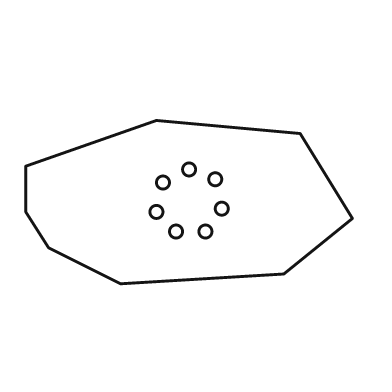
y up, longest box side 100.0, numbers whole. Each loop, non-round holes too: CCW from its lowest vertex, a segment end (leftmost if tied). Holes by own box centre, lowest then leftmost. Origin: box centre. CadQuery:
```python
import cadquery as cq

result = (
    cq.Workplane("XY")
    .moveTo(-21.0, -25.0)
    .lineTo(29.0, -22.0)
    .lineTo(50.0, -5.0)
    .lineTo(34.0, 21.0)
    .lineTo(-10.0, 25.0)
    .lineTo(-50.0, 11.0)
    .lineTo(-50.0, -3.0)
    .lineTo(-43.0, -14.0)
    .close()
    .moveTo(-4.0, -9.0)
    .circle(2.0)
    .moveTo(5.0, -9.0)
    .circle(2.0)
    .moveTo(-10.0, -3.0)
    .circle(2.0)
    .moveTo(10.0, -2.0)
    .circle(2.0)
    .moveTo(-8.0, 6.0)
    .circle(2.0)
    .moveTo(8.0, 7.0)
    .circle(2.0)
    .moveTo(0.0, 10.0)
    .circle(2.0)
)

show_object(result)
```